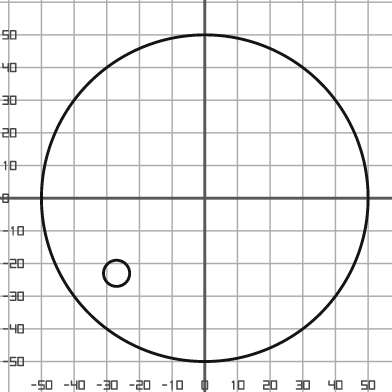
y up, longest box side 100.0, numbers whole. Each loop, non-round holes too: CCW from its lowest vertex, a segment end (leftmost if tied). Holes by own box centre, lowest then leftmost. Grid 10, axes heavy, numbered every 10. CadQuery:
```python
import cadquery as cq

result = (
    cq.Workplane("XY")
    .moveTo(0.0, 0.0)
    .circle(50.0)
    .moveTo(-27.0, -23.0)
    .circle(4.0)
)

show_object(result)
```